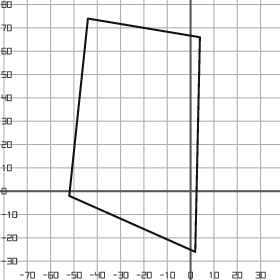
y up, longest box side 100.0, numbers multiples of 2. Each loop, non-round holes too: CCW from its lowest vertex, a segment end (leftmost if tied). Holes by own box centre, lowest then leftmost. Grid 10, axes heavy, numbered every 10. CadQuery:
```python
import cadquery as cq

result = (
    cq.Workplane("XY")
    .moveTo(2.0, -26.0)
    .lineTo(4.0, 66.0)
    .lineTo(-44.0, 74.0)
    .lineTo(-52.0, -2.0)
    .close()
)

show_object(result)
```